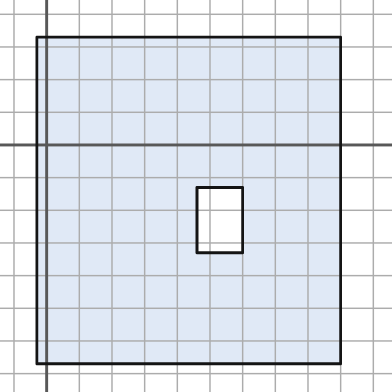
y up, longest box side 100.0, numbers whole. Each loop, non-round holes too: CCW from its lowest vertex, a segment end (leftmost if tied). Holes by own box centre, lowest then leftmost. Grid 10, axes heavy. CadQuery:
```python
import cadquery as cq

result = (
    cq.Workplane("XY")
    .moveTo(-3.0, -67.0)
    .lineTo(90.0, -67.0)
    .lineTo(90.0, 33.0)
    .lineTo(-3.0, 33.0)
    .close()
    .moveTo(46.0, -33.0)
    .lineTo(60.0, -33.0)
    .lineTo(60.0, -13.0)
    .lineTo(46.0, -13.0)
    .close()
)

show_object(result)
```